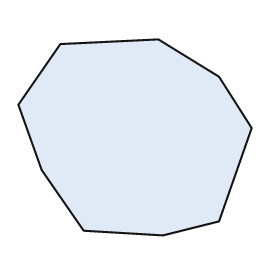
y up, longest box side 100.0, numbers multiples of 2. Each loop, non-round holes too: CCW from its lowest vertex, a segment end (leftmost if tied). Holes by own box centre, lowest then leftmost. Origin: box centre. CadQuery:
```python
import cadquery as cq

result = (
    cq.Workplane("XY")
    .moveTo(12.0, -42.0)
    .lineTo(36.0, -36.0)
    .lineTo(50.0, 4.0)
    .lineTo(36.0, 26.0)
    .lineTo(10.0, 42.0)
    .lineTo(-32.0, 40.0)
    .lineTo(-50.0, 14.0)
    .lineTo(-40.0, -14.0)
    .lineTo(-22.0, -40.0)
    .close()
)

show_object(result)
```